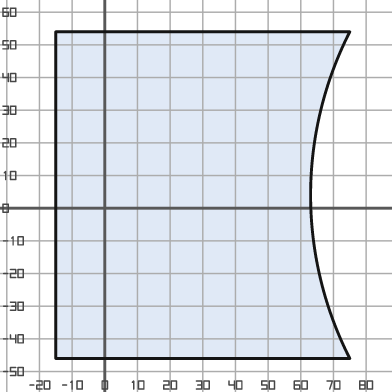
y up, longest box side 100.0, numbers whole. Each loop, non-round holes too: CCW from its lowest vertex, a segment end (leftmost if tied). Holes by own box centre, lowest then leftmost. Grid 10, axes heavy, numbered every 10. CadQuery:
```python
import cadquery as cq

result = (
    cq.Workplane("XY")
    .moveTo(-15.0, -46.0)
    .lineTo(75.0, -46.0)
    .threePointArc((63.0, 4.0), (75.0, 54.0))
    .lineTo(-15.0, 54.0)
    .close()
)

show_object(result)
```